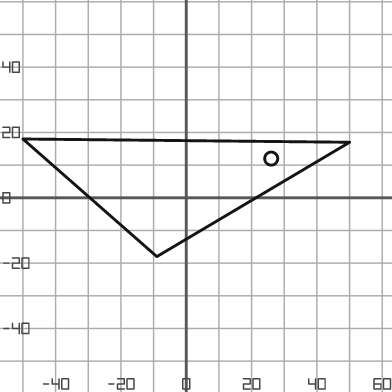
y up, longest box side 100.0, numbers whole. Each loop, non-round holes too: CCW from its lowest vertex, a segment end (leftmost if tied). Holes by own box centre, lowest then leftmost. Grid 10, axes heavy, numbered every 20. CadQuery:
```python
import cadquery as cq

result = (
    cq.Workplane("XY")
    .moveTo(-9.0, -18.0)
    .lineTo(50.0, 17.0)
    .lineTo(-50.0, 18.0)
    .close()
    .moveTo(26.0, 12.0)
    .circle(2.0)
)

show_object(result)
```